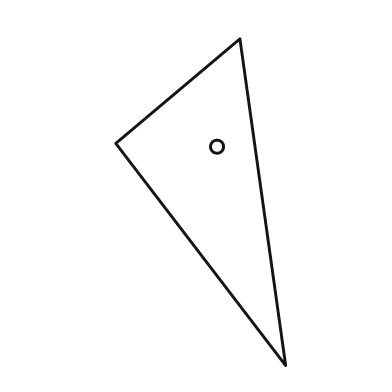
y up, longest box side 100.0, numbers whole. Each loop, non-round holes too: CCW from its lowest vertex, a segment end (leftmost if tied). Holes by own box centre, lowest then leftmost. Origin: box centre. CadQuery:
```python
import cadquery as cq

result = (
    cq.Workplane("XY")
    .moveTo(26.0, -50.0)
    .lineTo(12.0, 50.0)
    .lineTo(-26.0, 18.0)
    .close()
    .moveTo(5.0, 17.0)
    .circle(2.0)
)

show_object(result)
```